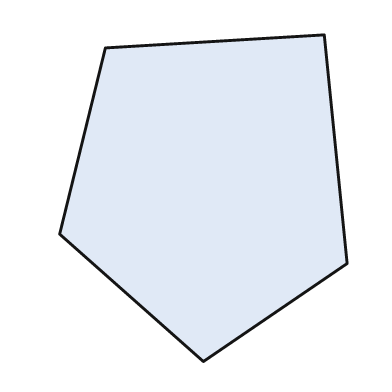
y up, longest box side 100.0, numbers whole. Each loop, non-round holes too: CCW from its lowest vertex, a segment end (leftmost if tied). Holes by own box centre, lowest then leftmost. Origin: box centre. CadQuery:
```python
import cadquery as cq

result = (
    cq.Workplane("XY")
    .moveTo(0.0, -50.0)
    .lineTo(44.0, -20.0)
    .lineTo(37.0, 50.0)
    .lineTo(-30.0, 46.0)
    .lineTo(-44.0, -11.0)
    .close()
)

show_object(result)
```